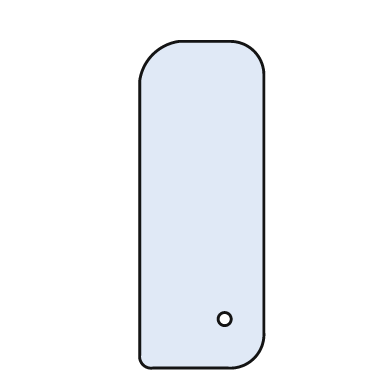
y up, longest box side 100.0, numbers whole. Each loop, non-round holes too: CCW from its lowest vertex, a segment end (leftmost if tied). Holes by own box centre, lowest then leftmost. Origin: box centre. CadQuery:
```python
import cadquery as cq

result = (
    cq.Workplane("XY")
    .moveTo(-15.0, -50.0)
    .lineTo(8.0, -50.0)
    .threePointArc((16.0, -47.0), (19.0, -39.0))
    .lineTo(19.0, 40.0)
    .threePointArc((16.0, 47.0), (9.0, 50.0))
    .lineTo(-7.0, 50.0)
    .threePointArc((-15.0, 46.0), (-19.0, 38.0))
    .lineTo(-19.0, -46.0)
    .threePointArc((-18.0, -49.0), (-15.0, -50.0))
    .close()
    .moveTo(7.0, -35.0)
    .circle(2.0)
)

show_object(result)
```